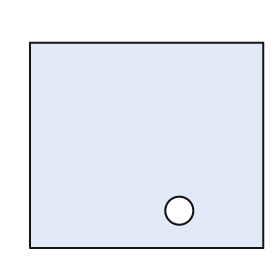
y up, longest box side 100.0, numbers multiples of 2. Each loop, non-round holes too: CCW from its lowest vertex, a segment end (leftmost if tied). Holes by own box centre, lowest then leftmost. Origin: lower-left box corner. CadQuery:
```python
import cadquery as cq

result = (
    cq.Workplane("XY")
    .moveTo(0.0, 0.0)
    .lineTo(100.0, 0.0)
    .lineTo(100.0, 88.0)
    .lineTo(0.0, 88.0)
    .close()
    .moveTo(64.0, 16.0)
    .circle(6.0)
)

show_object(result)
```